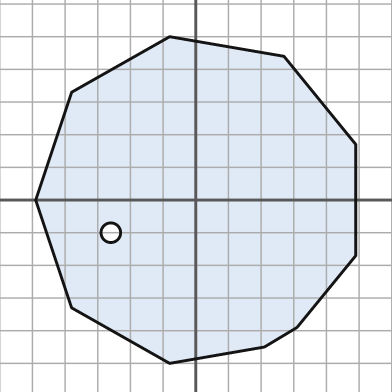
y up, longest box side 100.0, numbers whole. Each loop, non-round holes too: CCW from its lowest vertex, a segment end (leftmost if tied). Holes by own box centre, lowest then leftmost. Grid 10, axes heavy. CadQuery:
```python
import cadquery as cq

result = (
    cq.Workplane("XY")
    .moveTo(-8.0, -50.0)
    .lineTo(21.0, -45.0)
    .lineTo(31.0, -39.0)
    .lineTo(49.0, -17.0)
    .lineTo(49.0, 17.0)
    .lineTo(27.0, 44.0)
    .lineTo(-8.0, 50.0)
    .lineTo(-38.0, 33.0)
    .lineTo(-49.0, 0.0)
    .lineTo(-38.0, -33.0)
    .close()
    .moveTo(-26.0, -10.0)
    .circle(3.0)
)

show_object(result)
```